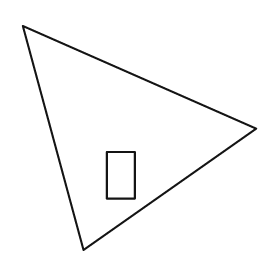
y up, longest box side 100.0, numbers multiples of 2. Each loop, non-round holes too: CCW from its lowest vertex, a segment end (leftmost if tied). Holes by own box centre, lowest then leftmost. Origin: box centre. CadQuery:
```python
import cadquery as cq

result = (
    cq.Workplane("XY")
    .moveTo(-24.0, -48.0)
    .lineTo(50.0, 4.0)
    .lineTo(-50.0, 48.0)
    .close()
    .moveTo(-14.0, -26.0)
    .lineTo(-2.0, -26.0)
    .lineTo(-2.0, -6.0)
    .lineTo(-14.0, -6.0)
    .close()
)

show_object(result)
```